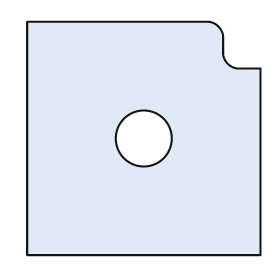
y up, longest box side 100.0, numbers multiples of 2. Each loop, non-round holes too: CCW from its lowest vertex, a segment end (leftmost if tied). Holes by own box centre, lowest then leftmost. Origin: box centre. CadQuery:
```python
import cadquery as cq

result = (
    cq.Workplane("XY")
    .moveTo(-50.0, -50.0)
    .lineTo(50.0, -50.0)
    .lineTo(50.0, 30.0)
    .lineTo(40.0, 30.0)
    .threePointArc((36.0, 32.0), (34.0, 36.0))
    .lineTo(34.0, 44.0)
    .threePointArc((32.0, 48.0), (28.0, 50.0))
    .lineTo(-50.0, 50.0)
    .close()
    .moveTo(0.0, 0.0)
    .circle(12.0)
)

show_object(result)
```